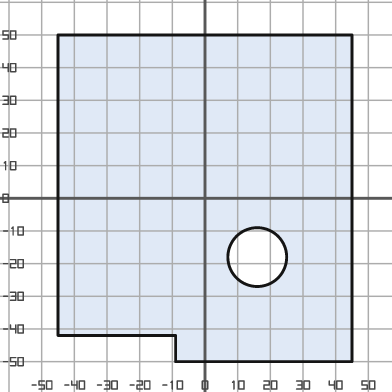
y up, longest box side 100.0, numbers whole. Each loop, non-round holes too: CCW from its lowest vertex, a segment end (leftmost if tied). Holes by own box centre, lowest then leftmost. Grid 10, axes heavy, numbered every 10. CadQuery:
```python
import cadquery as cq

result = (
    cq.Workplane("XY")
    .moveTo(-9.0, -50.0)
    .lineTo(45.0, -50.0)
    .lineTo(45.0, 50.0)
    .lineTo(-45.0, 50.0)
    .lineTo(-45.0, -42.0)
    .lineTo(-9.0, -42.0)
    .close()
    .moveTo(16.0, -18.0)
    .circle(9.0)
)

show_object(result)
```